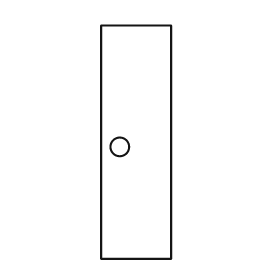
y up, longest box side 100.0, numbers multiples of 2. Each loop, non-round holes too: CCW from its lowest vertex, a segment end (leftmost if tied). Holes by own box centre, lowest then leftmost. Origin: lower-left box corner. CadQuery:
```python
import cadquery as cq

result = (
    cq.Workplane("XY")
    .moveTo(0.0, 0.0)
    .lineTo(30.0, 0.0)
    .lineTo(30.0, 100.0)
    .lineTo(0.0, 100.0)
    .close()
    .moveTo(8.0, 48.0)
    .circle(4.0)
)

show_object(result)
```